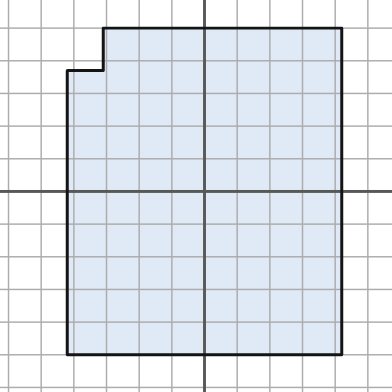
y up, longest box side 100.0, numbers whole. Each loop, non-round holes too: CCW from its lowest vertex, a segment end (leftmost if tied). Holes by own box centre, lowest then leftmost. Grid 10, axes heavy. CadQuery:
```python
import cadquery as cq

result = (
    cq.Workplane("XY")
    .moveTo(-42.0, -50.0)
    .lineTo(42.0, -50.0)
    .lineTo(42.0, 50.0)
    .lineTo(-31.0, 50.0)
    .lineTo(-31.0, 37.0)
    .lineTo(-42.0, 37.0)
    .close()
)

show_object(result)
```